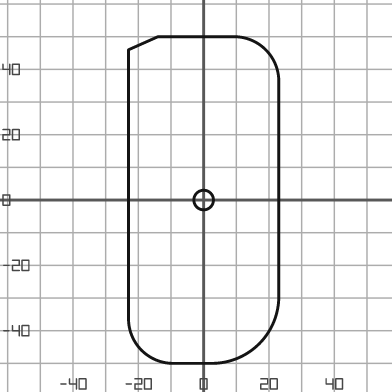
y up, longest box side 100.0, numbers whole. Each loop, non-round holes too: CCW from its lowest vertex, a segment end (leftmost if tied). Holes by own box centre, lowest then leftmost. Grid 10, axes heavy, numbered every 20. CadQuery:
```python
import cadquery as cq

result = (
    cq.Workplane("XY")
    .moveTo(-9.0, -50.0)
    .lineTo(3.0, -50.0)
    .threePointArc((17.0, -44.0), (23.0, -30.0))
    .lineTo(23.0, 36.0)
    .threePointArc((19.0, 46.0), (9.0, 50.0))
    .lineTo(-14.0, 50.0)
    .lineTo(-23.0, 46.0)
    .lineTo(-23.0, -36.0)
    .threePointArc((-19.0, -46.0), (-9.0, -50.0))
    .close()
    .moveTo(0.0, 0.0)
    .circle(3.0)
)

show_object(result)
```